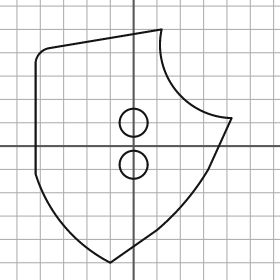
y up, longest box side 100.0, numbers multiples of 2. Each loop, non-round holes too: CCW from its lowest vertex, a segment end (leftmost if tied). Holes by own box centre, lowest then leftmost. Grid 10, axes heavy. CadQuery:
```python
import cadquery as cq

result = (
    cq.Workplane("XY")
    .moveTo(-10.0, -50.0)
    .lineTo(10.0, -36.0)
    .threePointArc((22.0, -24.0), (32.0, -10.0))
    .lineTo(42.0, 12.0)
    .threePointArc((18.0, 24.0), (12.0, 50.0))
    .lineTo(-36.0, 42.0)
    .threePointArc((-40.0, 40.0), (-42.0, 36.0))
    .lineTo(-42.0, -12.0)
    .threePointArc((-30.0, -34.0), (-10.0, -50.0))
    .close()
    .moveTo(0.0, -8.0)
    .circle(6.0)
    .moveTo(0.0, 10.0)
    .circle(6.0)
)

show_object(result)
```